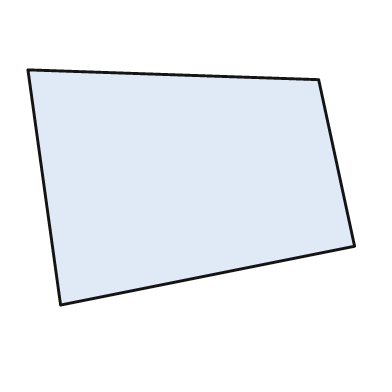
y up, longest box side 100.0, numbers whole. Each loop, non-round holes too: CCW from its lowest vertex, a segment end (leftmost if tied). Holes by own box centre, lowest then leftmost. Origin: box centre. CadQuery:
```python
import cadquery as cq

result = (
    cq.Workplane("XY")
    .moveTo(-40.0, -36.0)
    .lineTo(50.0, -18.0)
    .lineTo(39.0, 33.0)
    .lineTo(-50.0, 36.0)
    .close()
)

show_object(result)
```